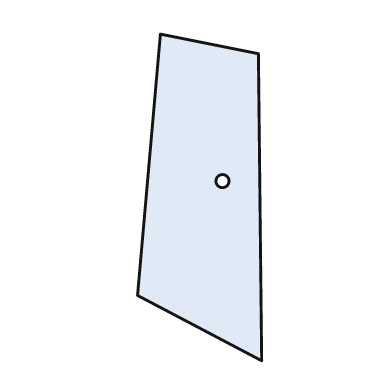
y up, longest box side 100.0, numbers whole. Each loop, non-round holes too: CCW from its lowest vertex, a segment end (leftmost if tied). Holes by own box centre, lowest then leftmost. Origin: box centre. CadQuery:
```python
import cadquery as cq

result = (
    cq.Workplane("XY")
    .moveTo(19.0, -50.0)
    .lineTo(18.0, 44.0)
    .lineTo(-12.0, 50.0)
    .lineTo(-19.0, -30.0)
    .close()
    .moveTo(7.0, 5.0)
    .circle(2.0)
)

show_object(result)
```